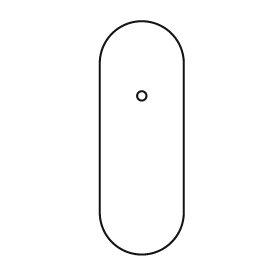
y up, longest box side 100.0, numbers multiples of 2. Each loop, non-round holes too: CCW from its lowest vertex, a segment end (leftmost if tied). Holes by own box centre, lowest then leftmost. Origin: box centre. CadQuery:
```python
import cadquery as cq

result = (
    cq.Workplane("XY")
    .moveTo(-18.0, -32.0)
    .threePointArc((0.0, -50.0), (18.0, -32.0))
    .lineTo(18.0, 32.0)
    .threePointArc((0.0, 50.0), (-18.0, 32.0))
    .close()
    .moveTo(0.0, 18.0)
    .circle(2.0)
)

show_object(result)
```